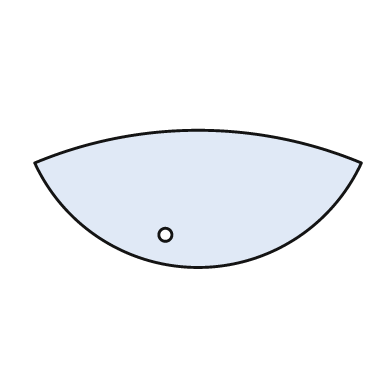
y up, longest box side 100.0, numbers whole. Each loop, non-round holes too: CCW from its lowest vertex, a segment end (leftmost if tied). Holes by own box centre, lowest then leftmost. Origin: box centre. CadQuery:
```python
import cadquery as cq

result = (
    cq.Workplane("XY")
    .moveTo(-50.0, 11.0)
    .threePointArc((0.0, -21.0), (50.0, 11.0))
    .threePointArc((0.0, 21.0), (-50.0, 11.0))
    .close()
    .moveTo(-10.0, -11.0)
    .circle(2.0)
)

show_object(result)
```